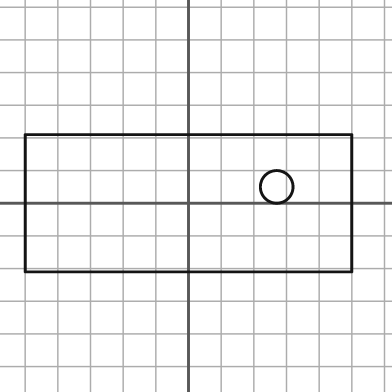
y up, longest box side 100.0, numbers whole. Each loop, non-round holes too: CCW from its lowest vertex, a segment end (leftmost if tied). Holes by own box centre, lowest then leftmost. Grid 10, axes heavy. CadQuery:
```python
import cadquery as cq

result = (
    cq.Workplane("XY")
    .moveTo(-50.0, -21.0)
    .lineTo(50.0, -21.0)
    .lineTo(50.0, 21.0)
    .lineTo(-50.0, 21.0)
    .close()
    .moveTo(27.0, 5.0)
    .circle(5.0)
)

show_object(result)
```